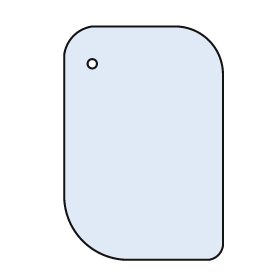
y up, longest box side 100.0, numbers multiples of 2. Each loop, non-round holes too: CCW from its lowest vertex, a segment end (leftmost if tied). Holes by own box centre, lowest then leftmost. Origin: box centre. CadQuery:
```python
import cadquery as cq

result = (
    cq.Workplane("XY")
    .moveTo(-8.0, -50.0)
    .lineTo(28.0, -50.0)
    .threePointArc((32.0, -48.0), (34.0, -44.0))
    .lineTo(34.0, 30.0)
    .threePointArc((28.0, 44.0), (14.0, 50.0))
    .lineTo(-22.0, 50.0)
    .threePointArc((-30.0, 46.0), (-34.0, 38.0))
    .lineTo(-34.0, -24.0)
    .threePointArc((-26.0, -42.0), (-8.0, -50.0))
    .close()
    .moveTo(-22.0, 34.0)
    .circle(2.0)
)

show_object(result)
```